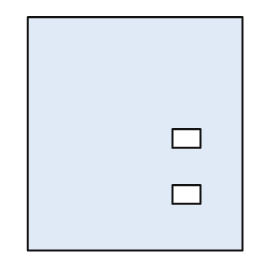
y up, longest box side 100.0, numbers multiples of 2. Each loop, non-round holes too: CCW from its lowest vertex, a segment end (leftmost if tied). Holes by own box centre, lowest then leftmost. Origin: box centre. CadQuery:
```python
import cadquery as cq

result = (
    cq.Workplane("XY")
    .moveTo(-46.0, -50.0)
    .lineTo(46.0, -50.0)
    .lineTo(46.0, 50.0)
    .lineTo(-46.0, 50.0)
    .close()
    .moveTo(16.0, -30.0)
    .lineTo(28.0, -30.0)
    .lineTo(28.0, -22.0)
    .lineTo(16.0, -22.0)
    .close()
    .moveTo(16.0, -6.0)
    .lineTo(28.0, -6.0)
    .lineTo(28.0, 2.0)
    .lineTo(16.0, 2.0)
    .close()
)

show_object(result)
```